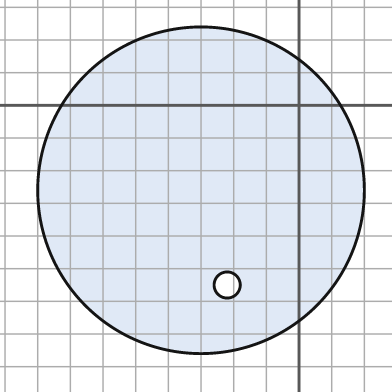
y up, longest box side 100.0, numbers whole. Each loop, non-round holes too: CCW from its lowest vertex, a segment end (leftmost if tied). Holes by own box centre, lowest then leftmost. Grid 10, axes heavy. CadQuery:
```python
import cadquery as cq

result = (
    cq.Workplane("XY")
    .moveTo(-30.0, -26.0)
    .circle(50.0)
    .moveTo(-22.0, -55.0)
    .circle(4.0)
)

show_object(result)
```